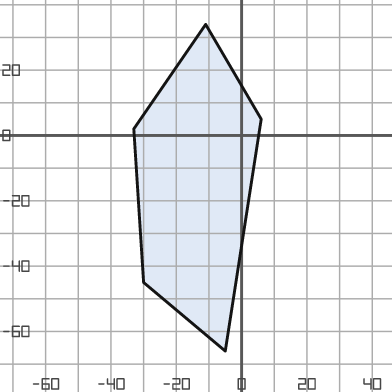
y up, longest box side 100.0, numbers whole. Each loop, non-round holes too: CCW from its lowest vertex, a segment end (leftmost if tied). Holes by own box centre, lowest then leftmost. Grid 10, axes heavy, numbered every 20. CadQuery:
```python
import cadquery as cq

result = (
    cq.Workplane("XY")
    .moveTo(-5.0, -66.0)
    .lineTo(6.0, 5.0)
    .lineTo(-11.0, 34.0)
    .lineTo(-33.0, 2.0)
    .lineTo(-30.0, -45.0)
    .close()
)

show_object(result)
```